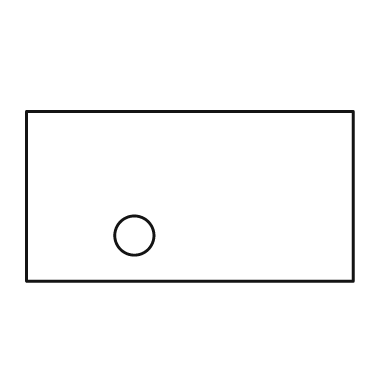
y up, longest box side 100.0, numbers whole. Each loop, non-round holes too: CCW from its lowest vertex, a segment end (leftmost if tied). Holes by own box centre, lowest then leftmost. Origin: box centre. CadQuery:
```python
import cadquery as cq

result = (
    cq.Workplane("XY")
    .moveTo(-50.0, -26.0)
    .lineTo(50.0, -26.0)
    .lineTo(50.0, 26.0)
    .lineTo(-50.0, 26.0)
    .close()
    .moveTo(-17.0, -12.0)
    .circle(6.0)
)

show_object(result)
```